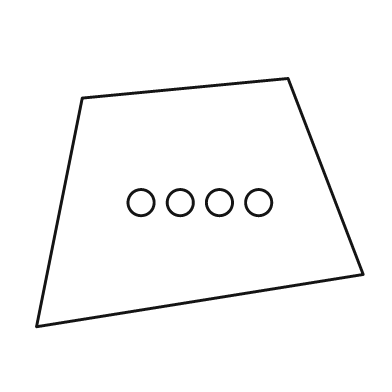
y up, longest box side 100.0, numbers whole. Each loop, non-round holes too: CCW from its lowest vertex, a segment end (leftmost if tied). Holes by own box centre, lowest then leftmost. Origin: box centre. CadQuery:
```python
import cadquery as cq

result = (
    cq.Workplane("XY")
    .moveTo(-50.0, -38.0)
    .lineTo(50.0, -22.0)
    .lineTo(27.0, 38.0)
    .lineTo(-36.0, 32.0)
    .close()
    .moveTo(-18.0, 0.0)
    .circle(4.0)
    .moveTo(-6.0, 0.0)
    .circle(4.0)
    .moveTo(6.0, 0.0)
    .circle(4.0)
    .moveTo(18.0, 0.0)
    .circle(4.0)
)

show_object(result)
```